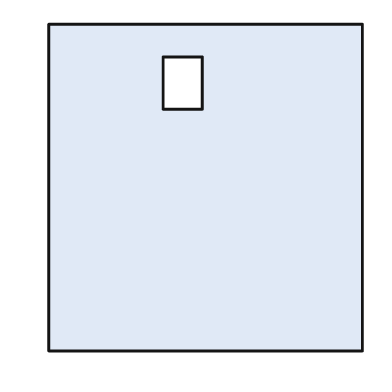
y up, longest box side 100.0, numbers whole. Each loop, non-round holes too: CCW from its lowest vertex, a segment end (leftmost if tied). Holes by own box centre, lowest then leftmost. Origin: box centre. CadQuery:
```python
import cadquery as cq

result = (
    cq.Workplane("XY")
    .moveTo(-48.0, -50.0)
    .lineTo(48.0, -50.0)
    .lineTo(48.0, 50.0)
    .lineTo(-48.0, 50.0)
    .close()
    .moveTo(-13.0, 24.0)
    .lineTo(-1.0, 24.0)
    .lineTo(-1.0, 40.0)
    .lineTo(-13.0, 40.0)
    .close()
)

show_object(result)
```